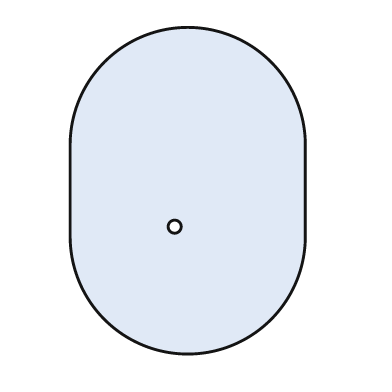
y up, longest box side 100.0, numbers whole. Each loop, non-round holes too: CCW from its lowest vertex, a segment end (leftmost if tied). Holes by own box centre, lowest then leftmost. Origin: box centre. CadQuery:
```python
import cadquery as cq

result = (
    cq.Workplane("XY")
    .moveTo(-36.0, -14.0)
    .threePointArc((0.0, -50.0), (36.0, -14.0))
    .lineTo(36.0, 14.0)
    .threePointArc((0.0, 50.0), (-36.0, 14.0))
    .close()
    .moveTo(-4.0, -11.0)
    .circle(2.0)
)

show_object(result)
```